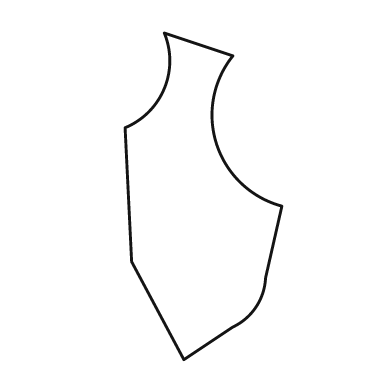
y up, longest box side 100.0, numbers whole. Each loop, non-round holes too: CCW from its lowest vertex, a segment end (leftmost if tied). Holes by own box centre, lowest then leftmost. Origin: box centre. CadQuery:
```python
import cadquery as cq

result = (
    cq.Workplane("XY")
    .moveTo(-6.0, -50.0)
    .lineTo(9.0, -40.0)
    .threePointArc((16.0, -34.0), (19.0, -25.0))
    .lineTo(24.0, -3.0)
    .threePointArc((4.0, 16.0), (9.0, 43.0))
    .lineTo(-12.0, 50.0)
    .threePointArc((-12.0, 33.0), (-24.0, 21.0))
    .lineTo(-22.0, -20.0)
    .close()
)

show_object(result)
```